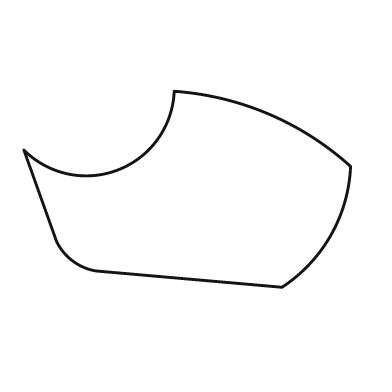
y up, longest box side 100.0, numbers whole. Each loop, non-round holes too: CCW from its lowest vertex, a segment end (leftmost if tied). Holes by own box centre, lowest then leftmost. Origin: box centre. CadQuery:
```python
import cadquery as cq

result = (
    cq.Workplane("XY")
    .moveTo(29.0, -30.0)
    .threePointArc((44.0, -14.0), (50.0, 7.0))
    .threePointArc((25.0, 23.0), (-4.0, 30.0))
    .threePointArc((-21.0, 6.0), (-50.0, 12.0))
    .lineTo(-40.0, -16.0)
    .threePointArc((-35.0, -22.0), (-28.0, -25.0))
    .close()
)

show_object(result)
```